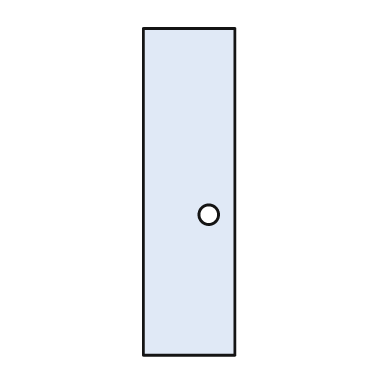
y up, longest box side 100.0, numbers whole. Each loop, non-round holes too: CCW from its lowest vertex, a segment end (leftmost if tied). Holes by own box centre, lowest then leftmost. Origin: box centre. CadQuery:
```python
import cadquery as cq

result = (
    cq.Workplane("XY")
    .moveTo(-14.0, -50.0)
    .lineTo(14.0, -50.0)
    .lineTo(14.0, 50.0)
    .lineTo(-14.0, 50.0)
    .close()
    .moveTo(6.0, -7.0)
    .circle(3.0)
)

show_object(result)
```